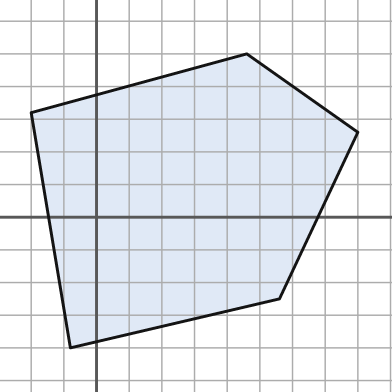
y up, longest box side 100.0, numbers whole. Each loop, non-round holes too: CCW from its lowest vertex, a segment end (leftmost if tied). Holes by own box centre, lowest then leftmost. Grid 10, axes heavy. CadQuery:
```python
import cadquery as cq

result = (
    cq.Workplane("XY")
    .moveTo(-8.0, -40.0)
    .lineTo(56.0, -25.0)
    .lineTo(80.0, 26.0)
    .lineTo(46.0, 50.0)
    .lineTo(-20.0, 32.0)
    .close()
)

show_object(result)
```